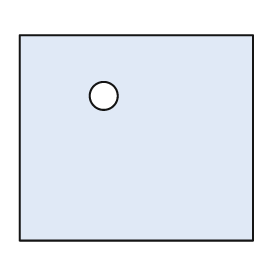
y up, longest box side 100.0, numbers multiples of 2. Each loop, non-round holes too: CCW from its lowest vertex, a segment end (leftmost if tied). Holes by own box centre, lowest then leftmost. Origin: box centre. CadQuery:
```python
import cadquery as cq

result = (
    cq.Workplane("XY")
    .moveTo(-50.0, -44.0)
    .lineTo(50.0, -44.0)
    .lineTo(50.0, 44.0)
    .lineTo(-50.0, 44.0)
    .close()
    .moveTo(-14.0, 18.0)
    .circle(6.0)
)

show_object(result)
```